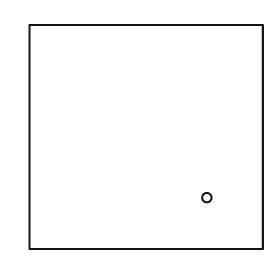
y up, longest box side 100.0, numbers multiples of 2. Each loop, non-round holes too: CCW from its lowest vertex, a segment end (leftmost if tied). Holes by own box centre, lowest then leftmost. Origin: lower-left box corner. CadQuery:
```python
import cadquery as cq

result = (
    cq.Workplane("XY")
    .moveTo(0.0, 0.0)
    .lineTo(100.0, 0.0)
    .lineTo(100.0, 96.0)
    .lineTo(0.0, 96.0)
    .close()
    .moveTo(76.0, 22.0)
    .circle(2.0)
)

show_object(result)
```